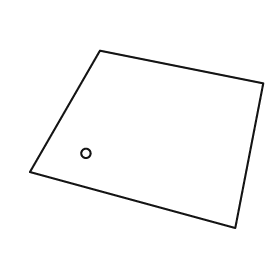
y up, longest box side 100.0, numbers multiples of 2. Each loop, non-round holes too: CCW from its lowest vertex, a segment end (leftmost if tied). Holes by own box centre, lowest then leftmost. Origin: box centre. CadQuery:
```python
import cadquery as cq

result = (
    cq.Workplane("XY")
    .moveTo(38.0, -38.0)
    .lineTo(50.0, 24.0)
    .lineTo(-20.0, 38.0)
    .lineTo(-50.0, -14.0)
    .close()
    .moveTo(-26.0, -6.0)
    .circle(2.0)
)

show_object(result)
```